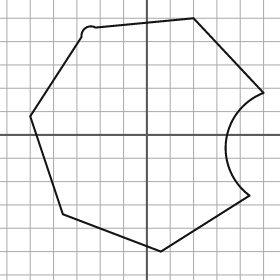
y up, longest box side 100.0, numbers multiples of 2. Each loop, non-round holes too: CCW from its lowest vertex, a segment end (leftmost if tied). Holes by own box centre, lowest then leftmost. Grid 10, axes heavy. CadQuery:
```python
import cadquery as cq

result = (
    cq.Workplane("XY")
    .moveTo(6.0, -50.0)
    .lineTo(44.0, -26.0)
    .threePointArc((34.0, -2.0), (50.0, 18.0))
    .lineTo(20.0, 50.0)
    .lineTo(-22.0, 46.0)
    .threePointArc((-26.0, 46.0), (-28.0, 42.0))
    .lineTo(-50.0, 8.0)
    .lineTo(-36.0, -34.0)
    .close()
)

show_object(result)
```